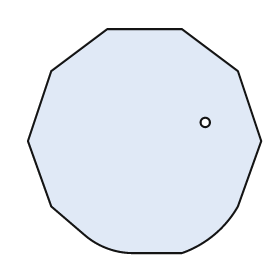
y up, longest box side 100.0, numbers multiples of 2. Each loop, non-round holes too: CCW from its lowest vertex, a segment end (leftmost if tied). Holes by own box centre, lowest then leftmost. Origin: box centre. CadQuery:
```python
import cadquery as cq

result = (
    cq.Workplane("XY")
    .moveTo(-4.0, -48.0)
    .lineTo(16.0, -48.0)
    .threePointArc((30.0, -40.0), (40.0, -28.0))
    .lineTo(50.0, 0.0)
    .lineTo(40.0, 30.0)
    .lineTo(16.0, 48.0)
    .lineTo(-16.0, 48.0)
    .lineTo(-40.0, 30.0)
    .lineTo(-50.0, 0.0)
    .lineTo(-40.0, -28.0)
    .lineTo(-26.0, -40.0)
    .threePointArc((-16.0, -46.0), (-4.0, -48.0))
    .close()
    .moveTo(26.0, 8.0)
    .circle(2.0)
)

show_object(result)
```